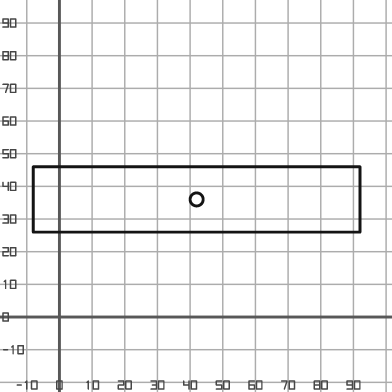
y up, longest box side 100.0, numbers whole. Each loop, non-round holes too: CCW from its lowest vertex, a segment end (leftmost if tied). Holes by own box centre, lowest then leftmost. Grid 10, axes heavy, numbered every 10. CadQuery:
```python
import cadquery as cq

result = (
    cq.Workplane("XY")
    .moveTo(-8.0, 26.0)
    .lineTo(92.0, 26.0)
    .lineTo(92.0, 46.0)
    .lineTo(-8.0, 46.0)
    .close()
    .moveTo(42.0, 36.0)
    .circle(2.0)
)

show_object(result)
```